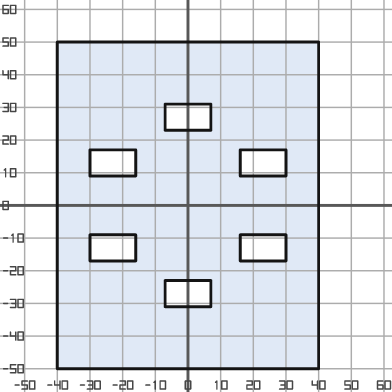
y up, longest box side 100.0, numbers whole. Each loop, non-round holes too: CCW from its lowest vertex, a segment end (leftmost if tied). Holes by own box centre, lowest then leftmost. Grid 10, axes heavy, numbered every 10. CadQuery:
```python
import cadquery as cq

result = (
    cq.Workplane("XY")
    .moveTo(-40.0, -50.0)
    .lineTo(40.0, -50.0)
    .lineTo(40.0, 50.0)
    .lineTo(-40.0, 50.0)
    .close()
    .moveTo(-7.0, -31.0)
    .lineTo(7.0, -31.0)
    .lineTo(7.0, -23.0)
    .lineTo(-7.0, -23.0)
    .close()
    .moveTo(-30.0, -17.0)
    .lineTo(-16.0, -17.0)
    .lineTo(-16.0, -9.0)
    .lineTo(-30.0, -9.0)
    .close()
    .moveTo(16.0, -17.0)
    .lineTo(30.0, -17.0)
    .lineTo(30.0, -9.0)
    .lineTo(16.0, -9.0)
    .close()
    .moveTo(-30.0, 9.0)
    .lineTo(-16.0, 9.0)
    .lineTo(-16.0, 17.0)
    .lineTo(-30.0, 17.0)
    .close()
    .moveTo(16.0, 9.0)
    .lineTo(30.0, 9.0)
    .lineTo(30.0, 17.0)
    .lineTo(16.0, 17.0)
    .close()
    .moveTo(-7.0, 23.0)
    .lineTo(7.0, 23.0)
    .lineTo(7.0, 31.0)
    .lineTo(-7.0, 31.0)
    .close()
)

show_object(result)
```